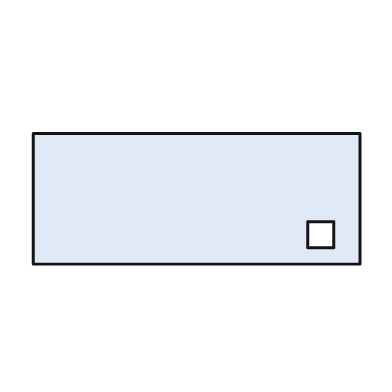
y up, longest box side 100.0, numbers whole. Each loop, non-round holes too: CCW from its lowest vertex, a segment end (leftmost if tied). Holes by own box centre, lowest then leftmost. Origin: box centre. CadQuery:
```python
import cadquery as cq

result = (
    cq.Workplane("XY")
    .moveTo(-50.0, -20.0)
    .lineTo(50.0, -20.0)
    .lineTo(50.0, 20.0)
    .lineTo(-50.0, 20.0)
    .close()
    .moveTo(34.0, -15.0)
    .lineTo(42.0, -15.0)
    .lineTo(42.0, -7.0)
    .lineTo(34.0, -7.0)
    .close()
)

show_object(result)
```